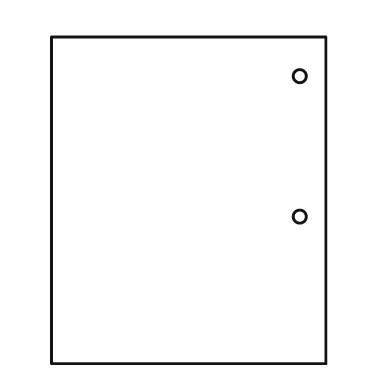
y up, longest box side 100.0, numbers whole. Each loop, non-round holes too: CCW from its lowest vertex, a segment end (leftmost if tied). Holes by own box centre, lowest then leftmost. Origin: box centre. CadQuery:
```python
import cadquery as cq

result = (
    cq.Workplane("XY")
    .moveTo(-42.0, -50.0)
    .lineTo(42.0, -50.0)
    .lineTo(42.0, 50.0)
    .lineTo(-42.0, 50.0)
    .close()
    .moveTo(34.0, -5.0)
    .circle(2.0)
    .moveTo(34.0, 38.0)
    .circle(2.0)
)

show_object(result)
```